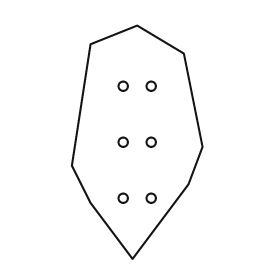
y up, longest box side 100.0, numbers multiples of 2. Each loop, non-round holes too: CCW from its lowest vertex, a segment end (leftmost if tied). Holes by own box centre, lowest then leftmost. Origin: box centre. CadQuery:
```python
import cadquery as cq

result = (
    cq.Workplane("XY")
    .moveTo(-2.0, -50.0)
    .lineTo(22.0, -18.0)
    .lineTo(28.0, -2.0)
    .lineTo(20.0, 38.0)
    .lineTo(0.0, 50.0)
    .lineTo(-20.0, 42.0)
    .lineTo(-28.0, -10.0)
    .lineTo(-20.0, -26.0)
    .close()
    .moveTo(-6.0, -24.0)
    .circle(2.0)
    .moveTo(6.0, -24.0)
    .circle(2.0)
    .moveTo(-6.0, 0.0)
    .circle(2.0)
    .moveTo(6.0, 0.0)
    .circle(2.0)
    .moveTo(-6.0, 24.0)
    .circle(2.0)
    .moveTo(6.0, 24.0)
    .circle(2.0)
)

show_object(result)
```